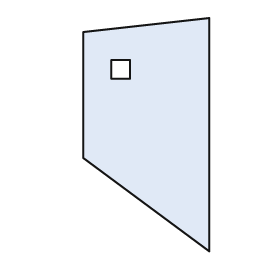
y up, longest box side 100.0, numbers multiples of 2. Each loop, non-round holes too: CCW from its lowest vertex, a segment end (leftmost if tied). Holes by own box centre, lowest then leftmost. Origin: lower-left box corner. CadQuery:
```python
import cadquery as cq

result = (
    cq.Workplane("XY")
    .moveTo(54.0, 0.0)
    .lineTo(54.0, 100.0)
    .lineTo(0.0, 94.0)
    .lineTo(0.0, 40.0)
    .close()
    .moveTo(12.0, 74.0)
    .lineTo(20.0, 74.0)
    .lineTo(20.0, 82.0)
    .lineTo(12.0, 82.0)
    .close()
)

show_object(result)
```